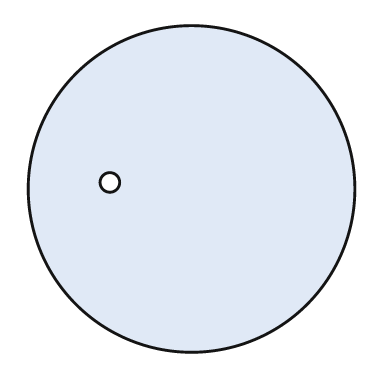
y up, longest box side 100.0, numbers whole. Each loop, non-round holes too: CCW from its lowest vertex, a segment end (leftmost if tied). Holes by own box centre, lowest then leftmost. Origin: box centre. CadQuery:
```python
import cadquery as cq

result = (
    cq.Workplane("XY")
    .moveTo(0.0, 0.0)
    .circle(50.0)
    .moveTo(-25.0, 2.0)
    .circle(3.0)
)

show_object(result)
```